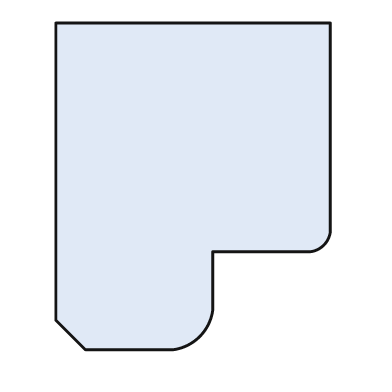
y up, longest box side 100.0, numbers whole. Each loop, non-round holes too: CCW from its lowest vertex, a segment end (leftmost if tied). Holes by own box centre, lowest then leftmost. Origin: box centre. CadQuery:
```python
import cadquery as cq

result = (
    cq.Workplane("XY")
    .moveTo(-33.0, -50.0)
    .lineTo(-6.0, -50.0)
    .threePointArc((2.0, -46.0), (6.0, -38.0))
    .lineTo(6.0, -20.0)
    .lineTo(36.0, -20.0)
    .threePointArc((40.0, -18.0), (42.0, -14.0))
    .lineTo(42.0, 50.0)
    .lineTo(-42.0, 50.0)
    .lineTo(-42.0, -41.0)
    .close()
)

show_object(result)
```